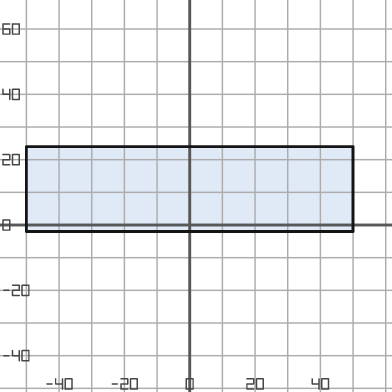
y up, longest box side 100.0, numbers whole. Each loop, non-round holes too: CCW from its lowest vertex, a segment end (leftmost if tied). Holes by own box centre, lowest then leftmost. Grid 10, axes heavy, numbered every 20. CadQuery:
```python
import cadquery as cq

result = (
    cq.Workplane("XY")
    .moveTo(-50.0, -2.0)
    .lineTo(50.0, -2.0)
    .lineTo(50.0, 24.0)
    .lineTo(-50.0, 24.0)
    .close()
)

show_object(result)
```